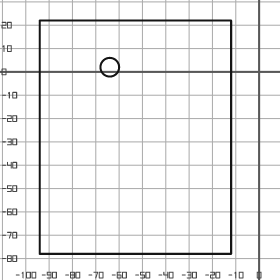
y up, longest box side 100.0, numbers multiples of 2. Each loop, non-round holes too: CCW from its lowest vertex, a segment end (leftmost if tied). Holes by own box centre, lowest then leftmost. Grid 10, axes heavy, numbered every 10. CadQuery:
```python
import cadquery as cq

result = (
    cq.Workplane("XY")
    .moveTo(-94.0, -78.0)
    .lineTo(-12.0, -78.0)
    .lineTo(-12.0, 22.0)
    .lineTo(-94.0, 22.0)
    .close()
    .moveTo(-64.0, 2.0)
    .circle(4.0)
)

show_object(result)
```